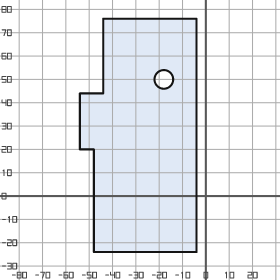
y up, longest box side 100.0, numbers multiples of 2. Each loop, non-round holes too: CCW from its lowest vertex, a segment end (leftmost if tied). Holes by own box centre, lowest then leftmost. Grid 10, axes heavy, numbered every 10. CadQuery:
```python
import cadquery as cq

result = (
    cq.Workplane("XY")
    .moveTo(-48.0, -24.0)
    .lineTo(-4.0, -24.0)
    .lineTo(-4.0, 76.0)
    .lineTo(-44.0, 76.0)
    .lineTo(-44.0, 44.0)
    .lineTo(-54.0, 44.0)
    .lineTo(-54.0, 20.0)
    .lineTo(-48.0, 20.0)
    .close()
    .moveTo(-18.0, 50.0)
    .circle(4.0)
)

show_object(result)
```